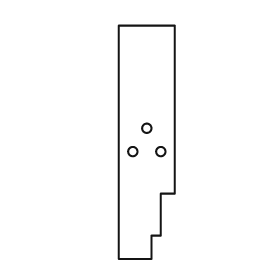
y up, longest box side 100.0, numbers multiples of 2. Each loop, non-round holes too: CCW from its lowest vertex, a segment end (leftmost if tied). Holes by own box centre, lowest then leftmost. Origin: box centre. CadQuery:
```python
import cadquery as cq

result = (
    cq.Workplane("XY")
    .moveTo(-12.0, -50.0)
    .lineTo(2.0, -50.0)
    .lineTo(2.0, -40.0)
    .lineTo(6.0, -40.0)
    .lineTo(6.0, -22.0)
    .lineTo(12.0, -22.0)
    .lineTo(12.0, 50.0)
    .lineTo(-12.0, 50.0)
    .close()
    .moveTo(-6.0, -4.0)
    .circle(2.0)
    .moveTo(6.0, -4.0)
    .circle(2.0)
    .moveTo(0.0, 6.0)
    .circle(2.0)
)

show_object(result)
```